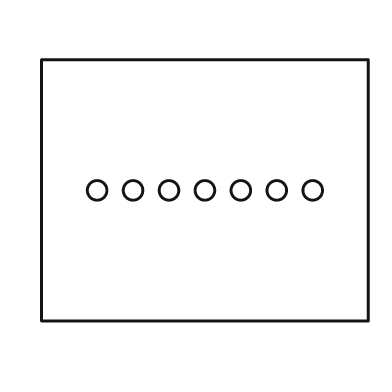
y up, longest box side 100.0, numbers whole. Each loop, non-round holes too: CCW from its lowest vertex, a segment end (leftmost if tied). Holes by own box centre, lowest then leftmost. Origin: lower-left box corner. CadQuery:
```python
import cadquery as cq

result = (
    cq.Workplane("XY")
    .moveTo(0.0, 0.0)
    .lineTo(100.0, 0.0)
    .lineTo(100.0, 80.0)
    .lineTo(0.0, 80.0)
    .close()
    .moveTo(17.0, 40.0)
    .circle(3.0)
    .moveTo(28.0, 40.0)
    .circle(3.0)
    .moveTo(39.0, 40.0)
    .circle(3.0)
    .moveTo(50.0, 40.0)
    .circle(3.0)
    .moveTo(61.0, 40.0)
    .circle(3.0)
    .moveTo(72.0, 40.0)
    .circle(3.0)
    .moveTo(83.0, 40.0)
    .circle(3.0)
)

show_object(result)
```